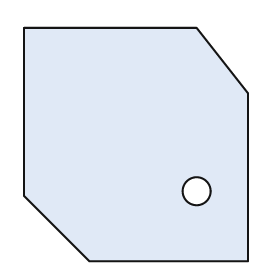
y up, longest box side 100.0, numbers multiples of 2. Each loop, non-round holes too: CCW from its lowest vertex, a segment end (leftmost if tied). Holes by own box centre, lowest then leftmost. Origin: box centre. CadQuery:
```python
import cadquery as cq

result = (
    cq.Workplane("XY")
    .moveTo(-20.0, -50.0)
    .lineTo(48.0, -50.0)
    .lineTo(48.0, 22.0)
    .lineTo(26.0, 50.0)
    .lineTo(-48.0, 50.0)
    .lineTo(-48.0, -22.0)
    .close()
    .moveTo(26.0, -20.0)
    .circle(6.0)
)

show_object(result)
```